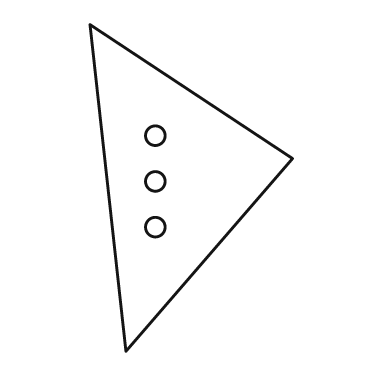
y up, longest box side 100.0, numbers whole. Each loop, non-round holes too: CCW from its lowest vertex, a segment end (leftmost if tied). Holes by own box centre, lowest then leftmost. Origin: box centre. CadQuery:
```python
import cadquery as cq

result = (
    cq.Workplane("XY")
    .moveTo(-20.0, -50.0)
    .lineTo(31.0, 9.0)
    .lineTo(-31.0, 50.0)
    .close()
    .moveTo(-11.0, -12.0)
    .circle(3.0)
    .moveTo(-11.0, 2.0)
    .circle(3.0)
    .moveTo(-11.0, 16.0)
    .circle(3.0)
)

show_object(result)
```